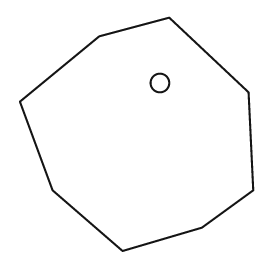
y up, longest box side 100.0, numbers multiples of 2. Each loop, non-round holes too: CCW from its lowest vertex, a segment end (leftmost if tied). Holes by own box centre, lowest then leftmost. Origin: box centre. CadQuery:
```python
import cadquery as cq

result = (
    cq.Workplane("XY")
    .moveTo(-6.0, -50.0)
    .lineTo(28.0, -40.0)
    .lineTo(50.0, -24.0)
    .lineTo(48.0, 18.0)
    .lineTo(14.0, 50.0)
    .lineTo(-16.0, 42.0)
    .lineTo(-50.0, 14.0)
    .lineTo(-36.0, -24.0)
    .close()
    .moveTo(10.0, 22.0)
    .circle(4.0)
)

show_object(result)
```